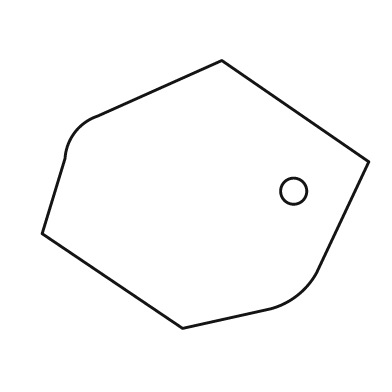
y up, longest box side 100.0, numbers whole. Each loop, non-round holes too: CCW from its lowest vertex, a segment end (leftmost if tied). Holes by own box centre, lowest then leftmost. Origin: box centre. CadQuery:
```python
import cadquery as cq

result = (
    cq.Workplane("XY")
    .moveTo(-7.0, -41.0)
    .lineTo(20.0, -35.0)
    .threePointArc((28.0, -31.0), (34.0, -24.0))
    .lineTo(50.0, 10.0)
    .lineTo(5.0, 41.0)
    .lineTo(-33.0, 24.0)
    .threePointArc((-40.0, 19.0), (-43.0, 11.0))
    .lineTo(-50.0, -12.0)
    .close()
    .moveTo(27.0, 1.0)
    .circle(4.0)
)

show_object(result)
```